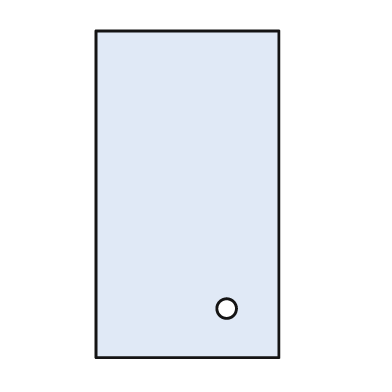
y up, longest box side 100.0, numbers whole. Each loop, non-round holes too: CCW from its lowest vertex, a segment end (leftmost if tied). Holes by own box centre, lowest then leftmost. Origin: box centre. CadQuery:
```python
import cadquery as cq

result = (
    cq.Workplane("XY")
    .moveTo(-28.0, -50.0)
    .lineTo(28.0, -50.0)
    .lineTo(28.0, 50.0)
    .lineTo(-28.0, 50.0)
    .close()
    .moveTo(12.0, -35.0)
    .circle(3.0)
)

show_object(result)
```